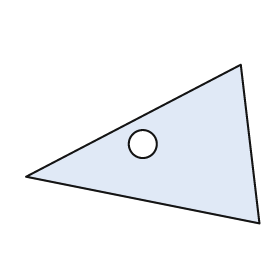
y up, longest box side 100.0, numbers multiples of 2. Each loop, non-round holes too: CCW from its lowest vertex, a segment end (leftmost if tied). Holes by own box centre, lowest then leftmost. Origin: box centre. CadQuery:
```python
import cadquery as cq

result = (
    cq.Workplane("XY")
    .moveTo(50.0, -34.0)
    .lineTo(42.0, 34.0)
    .lineTo(-50.0, -14.0)
    .close()
    .moveTo(0.0, 0.0)
    .circle(6.0)
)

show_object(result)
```